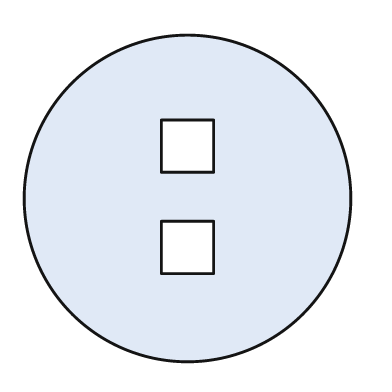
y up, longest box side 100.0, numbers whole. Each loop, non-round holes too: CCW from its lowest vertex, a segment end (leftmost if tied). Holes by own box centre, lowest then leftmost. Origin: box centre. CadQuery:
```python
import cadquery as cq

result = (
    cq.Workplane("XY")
    .moveTo(0.0, 0.0)
    .circle(50.0)
    .moveTo(-8.0, -23.0)
    .lineTo(8.0, -23.0)
    .lineTo(8.0, -7.0)
    .lineTo(-8.0, -7.0)
    .close()
    .moveTo(-8.0, 8.0)
    .lineTo(8.0, 8.0)
    .lineTo(8.0, 24.0)
    .lineTo(-8.0, 24.0)
    .close()
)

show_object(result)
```